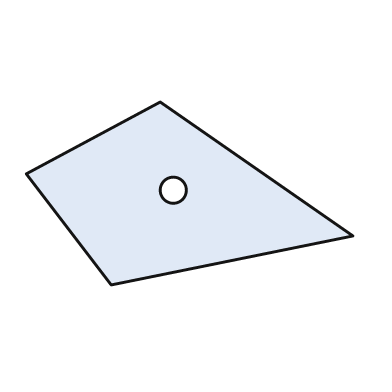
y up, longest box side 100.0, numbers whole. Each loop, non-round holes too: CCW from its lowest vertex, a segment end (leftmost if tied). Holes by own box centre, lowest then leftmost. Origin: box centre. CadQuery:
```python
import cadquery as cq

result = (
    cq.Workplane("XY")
    .moveTo(-24.0, -28.0)
    .lineTo(50.0, -13.0)
    .lineTo(-9.0, 28.0)
    .lineTo(-50.0, 6.0)
    .close()
    .moveTo(-5.0, 1.0)
    .circle(4.0)
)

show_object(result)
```